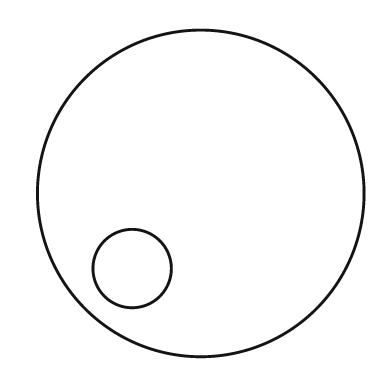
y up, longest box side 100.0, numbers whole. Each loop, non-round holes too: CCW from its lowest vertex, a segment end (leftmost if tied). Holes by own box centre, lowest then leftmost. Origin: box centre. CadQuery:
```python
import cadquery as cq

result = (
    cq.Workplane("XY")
    .moveTo(0.0, 0.0)
    .circle(50.0)
    .moveTo(-21.0, -23.0)
    .circle(12.0)
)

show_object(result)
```